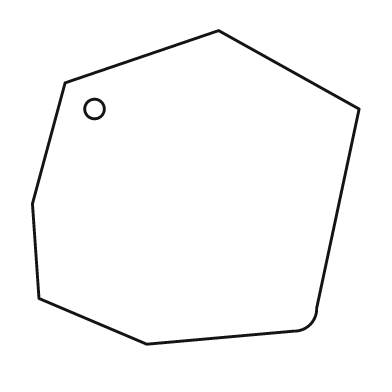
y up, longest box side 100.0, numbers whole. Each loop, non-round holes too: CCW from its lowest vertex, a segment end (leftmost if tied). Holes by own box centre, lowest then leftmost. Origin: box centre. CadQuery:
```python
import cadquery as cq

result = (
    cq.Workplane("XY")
    .moveTo(-15.0, -48.0)
    .lineTo(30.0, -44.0)
    .threePointArc((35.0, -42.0), (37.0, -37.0))
    .lineTo(50.0, 24.0)
    .lineTo(7.0, 48.0)
    .lineTo(-40.0, 32.0)
    .lineTo(-50.0, -5.0)
    .lineTo(-48.0, -34.0)
    .close()
    .moveTo(-31.0, 24.0)
    .circle(3.0)
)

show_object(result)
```